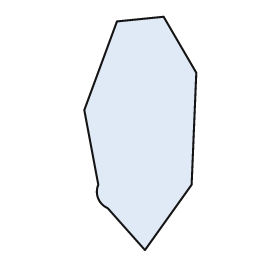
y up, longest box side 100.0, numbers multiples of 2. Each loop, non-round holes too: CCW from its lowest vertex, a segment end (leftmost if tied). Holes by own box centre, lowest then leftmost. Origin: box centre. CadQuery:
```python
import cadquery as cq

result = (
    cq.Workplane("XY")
    .moveTo(2.0, -50.0)
    .lineTo(22.0, -22.0)
    .lineTo(24.0, 26.0)
    .lineTo(10.0, 50.0)
    .lineTo(-10.0, 48.0)
    .lineTo(-24.0, 10.0)
    .lineTo(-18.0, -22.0)
    .threePointArc((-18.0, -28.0), (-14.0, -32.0))
    .close()
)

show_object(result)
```